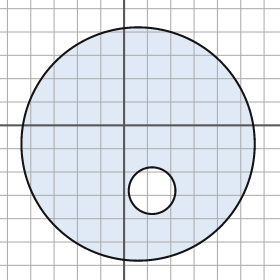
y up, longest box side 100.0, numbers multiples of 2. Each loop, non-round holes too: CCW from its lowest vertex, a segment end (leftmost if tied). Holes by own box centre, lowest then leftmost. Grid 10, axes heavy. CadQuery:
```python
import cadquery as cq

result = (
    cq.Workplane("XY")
    .moveTo(6.0, -8.0)
    .circle(50.0)
    .moveTo(12.0, -28.0)
    .circle(10.0)
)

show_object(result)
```